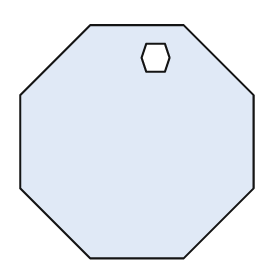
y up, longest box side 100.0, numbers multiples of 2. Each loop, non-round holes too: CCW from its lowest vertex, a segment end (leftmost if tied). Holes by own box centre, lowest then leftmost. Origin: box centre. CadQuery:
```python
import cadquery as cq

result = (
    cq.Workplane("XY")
    .moveTo(-20.0, -50.0)
    .lineTo(20.0, -50.0)
    .lineTo(50.0, -20.0)
    .lineTo(50.0, 20.0)
    .lineTo(20.0, 50.0)
    .lineTo(-20.0, 50.0)
    .lineTo(-50.0, 20.0)
    .lineTo(-50.0, -20.0)
    .close()
    .moveTo(4.0, 30.0)
    .lineTo(12.0, 30.0)
    .lineTo(14.0, 36.0)
    .lineTo(12.0, 42.0)
    .lineTo(4.0, 42.0)
    .lineTo(2.0, 36.0)
    .close()
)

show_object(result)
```